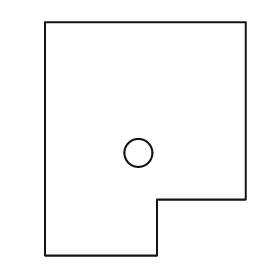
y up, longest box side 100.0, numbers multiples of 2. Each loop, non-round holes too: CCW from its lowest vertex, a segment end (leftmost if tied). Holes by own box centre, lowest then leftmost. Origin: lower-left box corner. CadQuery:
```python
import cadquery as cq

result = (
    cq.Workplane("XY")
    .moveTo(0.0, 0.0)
    .lineTo(48.0, 0.0)
    .lineTo(48.0, 24.0)
    .lineTo(86.0, 24.0)
    .lineTo(86.0, 100.0)
    .lineTo(0.0, 100.0)
    .close()
    .moveTo(40.0, 44.0)
    .circle(6.0)
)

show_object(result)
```